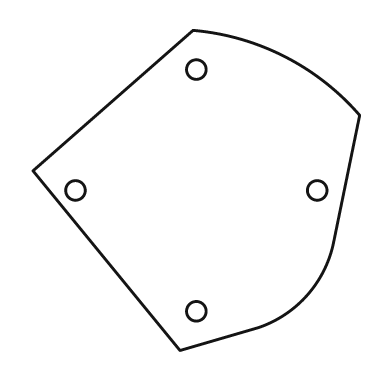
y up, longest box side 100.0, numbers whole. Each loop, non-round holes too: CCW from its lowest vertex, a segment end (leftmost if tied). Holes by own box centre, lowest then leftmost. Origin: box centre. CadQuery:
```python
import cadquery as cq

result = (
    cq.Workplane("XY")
    .moveTo(-5.0, -49.0)
    .lineTo(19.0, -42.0)
    .threePointArc((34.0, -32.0), (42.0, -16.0))
    .lineTo(50.0, 23.0)
    .threePointArc((27.0, 41.0), (-1.0, 49.0))
    .lineTo(-50.0, 6.0)
    .close()
    .moveTo(0.0, -37.0)
    .circle(3.0)
    .moveTo(-37.0, 0.0)
    .circle(3.0)
    .moveTo(37.0, 0.0)
    .circle(3.0)
    .moveTo(0.0, 37.0)
    .circle(3.0)
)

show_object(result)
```